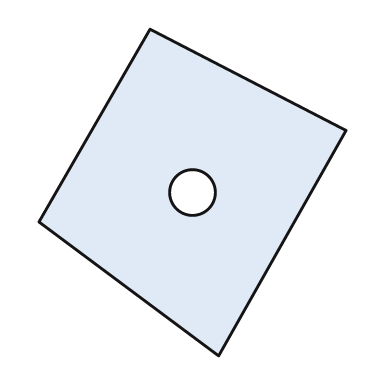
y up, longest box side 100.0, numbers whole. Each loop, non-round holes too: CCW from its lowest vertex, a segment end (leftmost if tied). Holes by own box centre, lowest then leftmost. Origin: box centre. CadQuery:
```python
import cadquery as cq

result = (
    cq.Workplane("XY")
    .moveTo(8.0, -50.0)
    .lineTo(47.0, 19.0)
    .lineTo(-13.0, 50.0)
    .lineTo(-47.0, -9.0)
    .close()
    .moveTo(0.0, 0.0)
    .circle(7.0)
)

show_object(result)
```